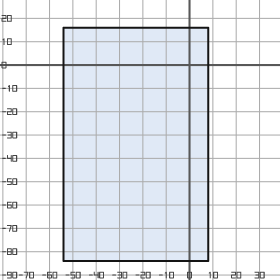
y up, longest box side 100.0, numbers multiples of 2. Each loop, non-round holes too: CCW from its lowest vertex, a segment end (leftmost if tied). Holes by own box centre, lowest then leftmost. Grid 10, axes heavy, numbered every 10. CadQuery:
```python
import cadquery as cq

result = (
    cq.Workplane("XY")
    .moveTo(-54.0, -84.0)
    .lineTo(8.0, -84.0)
    .lineTo(8.0, 16.0)
    .lineTo(-54.0, 16.0)
    .close()
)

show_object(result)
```